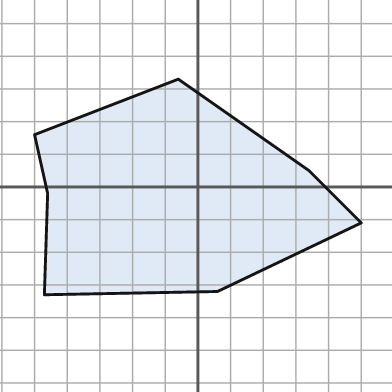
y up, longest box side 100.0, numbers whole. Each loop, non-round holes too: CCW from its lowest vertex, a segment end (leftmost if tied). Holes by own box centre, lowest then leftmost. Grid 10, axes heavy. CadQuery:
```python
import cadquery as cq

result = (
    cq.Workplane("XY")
    .moveTo(-47.0, -33.0)
    .lineTo(6.0, -32.0)
    .lineTo(50.0, -11.0)
    .lineTo(34.0, 5.0)
    .lineTo(-6.0, 33.0)
    .lineTo(-50.0, 16.0)
    .lineTo(-46.0, -2.0)
    .close()
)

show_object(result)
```